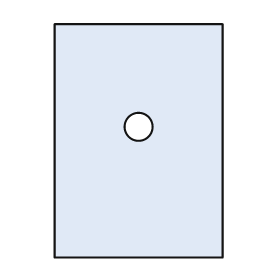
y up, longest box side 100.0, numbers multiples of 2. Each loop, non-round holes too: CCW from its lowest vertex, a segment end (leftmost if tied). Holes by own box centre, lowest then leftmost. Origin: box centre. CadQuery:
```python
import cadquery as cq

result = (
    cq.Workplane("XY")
    .moveTo(-36.0, -50.0)
    .lineTo(36.0, -50.0)
    .lineTo(36.0, 50.0)
    .lineTo(-36.0, 50.0)
    .close()
    .moveTo(0.0, 6.0)
    .circle(6.0)
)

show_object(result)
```